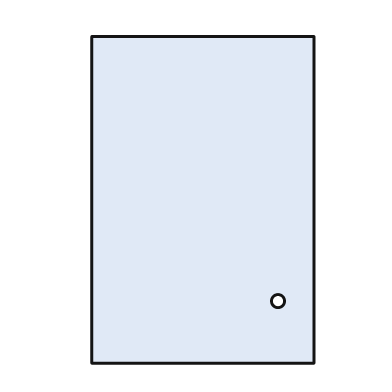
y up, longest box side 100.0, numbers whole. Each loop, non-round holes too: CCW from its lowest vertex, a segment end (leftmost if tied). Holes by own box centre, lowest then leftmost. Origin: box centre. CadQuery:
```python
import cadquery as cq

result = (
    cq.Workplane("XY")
    .moveTo(-34.0, -50.0)
    .lineTo(34.0, -50.0)
    .lineTo(34.0, 50.0)
    .lineTo(-34.0, 50.0)
    .close()
    .moveTo(23.0, -31.0)
    .circle(2.0)
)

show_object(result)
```